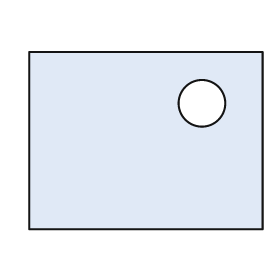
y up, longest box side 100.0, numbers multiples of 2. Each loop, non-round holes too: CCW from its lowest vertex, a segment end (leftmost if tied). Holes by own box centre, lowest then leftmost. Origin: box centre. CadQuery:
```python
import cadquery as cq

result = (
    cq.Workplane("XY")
    .moveTo(-50.0, -38.0)
    .lineTo(50.0, -38.0)
    .lineTo(50.0, 38.0)
    .lineTo(-50.0, 38.0)
    .close()
    .moveTo(24.0, 16.0)
    .circle(10.0)
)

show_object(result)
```